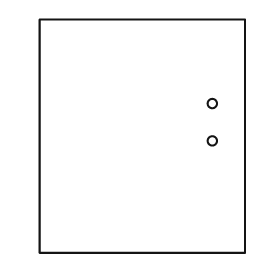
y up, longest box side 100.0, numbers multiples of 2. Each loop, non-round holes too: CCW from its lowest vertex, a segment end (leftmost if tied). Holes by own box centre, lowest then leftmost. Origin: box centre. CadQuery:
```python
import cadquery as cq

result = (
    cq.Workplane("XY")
    .moveTo(-44.0, -50.0)
    .lineTo(44.0, -50.0)
    .lineTo(44.0, 50.0)
    .lineTo(-44.0, 50.0)
    .close()
    .moveTo(30.0, -2.0)
    .circle(2.0)
    .moveTo(30.0, 14.0)
    .circle(2.0)
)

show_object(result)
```